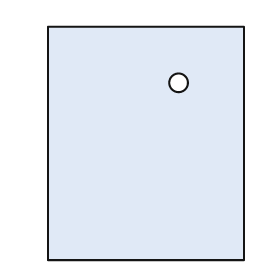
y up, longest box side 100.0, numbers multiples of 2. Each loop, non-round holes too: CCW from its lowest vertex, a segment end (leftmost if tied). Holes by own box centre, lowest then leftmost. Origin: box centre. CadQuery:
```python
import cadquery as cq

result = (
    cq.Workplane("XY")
    .moveTo(-42.0, -50.0)
    .lineTo(42.0, -50.0)
    .lineTo(42.0, 50.0)
    .lineTo(-42.0, 50.0)
    .close()
    .moveTo(14.0, 26.0)
    .circle(4.0)
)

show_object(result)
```